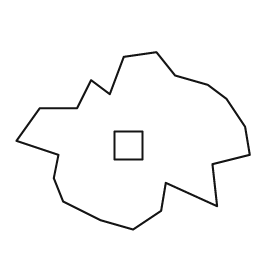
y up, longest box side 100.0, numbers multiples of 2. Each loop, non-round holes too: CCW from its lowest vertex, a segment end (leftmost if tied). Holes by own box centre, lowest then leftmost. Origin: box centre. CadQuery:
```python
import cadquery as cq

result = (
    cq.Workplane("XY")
    .moveTo(0.0, -38.0)
    .lineTo(12.0, -30.0)
    .lineTo(14.0, -18.0)
    .lineTo(36.0, -28.0)
    .lineTo(34.0, -10.0)
    .lineTo(50.0, -6.0)
    .lineTo(48.0, 6.0)
    .lineTo(40.0, 18.0)
    .lineTo(32.0, 24.0)
    .lineTo(18.0, 28.0)
    .lineTo(10.0, 38.0)
    .lineTo(-4.0, 36.0)
    .lineTo(-10.0, 20.0)
    .lineTo(-18.0, 26.0)
    .lineTo(-24.0, 14.0)
    .lineTo(-40.0, 14.0)
    .lineTo(-50.0, 0.0)
    .lineTo(-32.0, -6.0)
    .lineTo(-34.0, -16.0)
    .lineTo(-30.0, -26.0)
    .lineTo(-14.0, -34.0)
    .close()
    .moveTo(-8.0, -8.0)
    .lineTo(4.0, -8.0)
    .lineTo(4.0, 4.0)
    .lineTo(-8.0, 4.0)
    .close()
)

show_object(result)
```